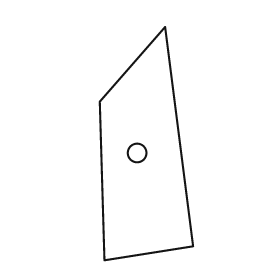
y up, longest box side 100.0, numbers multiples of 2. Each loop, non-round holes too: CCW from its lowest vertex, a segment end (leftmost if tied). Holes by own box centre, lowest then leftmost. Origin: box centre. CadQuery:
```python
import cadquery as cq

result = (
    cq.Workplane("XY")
    .moveTo(-18.0, -50.0)
    .lineTo(20.0, -44.0)
    .lineTo(8.0, 50.0)
    .lineTo(-20.0, 18.0)
    .close()
    .moveTo(-4.0, -4.0)
    .circle(4.0)
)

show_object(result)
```